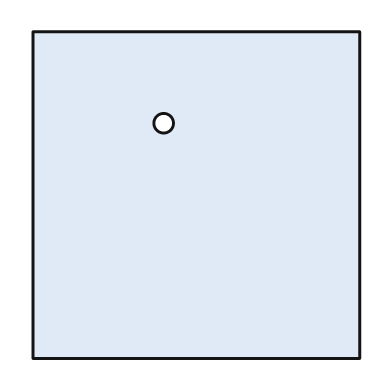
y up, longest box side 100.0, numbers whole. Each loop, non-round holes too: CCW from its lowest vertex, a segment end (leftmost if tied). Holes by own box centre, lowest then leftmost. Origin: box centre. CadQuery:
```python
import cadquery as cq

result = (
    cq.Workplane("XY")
    .moveTo(-50.0, -50.0)
    .lineTo(50.0, -50.0)
    .lineTo(50.0, 50.0)
    .lineTo(-50.0, 50.0)
    .close()
    .moveTo(-10.0, 22.0)
    .circle(3.0)
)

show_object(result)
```